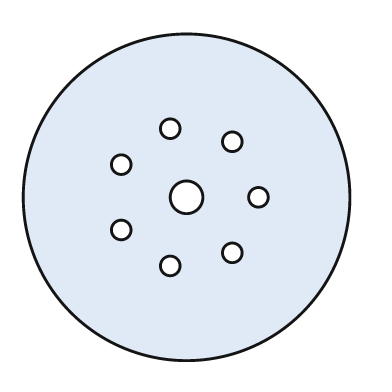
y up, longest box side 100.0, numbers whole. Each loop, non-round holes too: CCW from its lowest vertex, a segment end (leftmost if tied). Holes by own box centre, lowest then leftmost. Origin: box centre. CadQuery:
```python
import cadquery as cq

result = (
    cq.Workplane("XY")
    .moveTo(0.0, 0.0)
    .circle(50.0)
    .moveTo(-5.0, -21.0)
    .circle(3.0)
    .moveTo(14.0, -17.0)
    .circle(3.0)
    .moveTo(-20.0, -10.0)
    .circle(3.0)
    .moveTo(0.0, 0.0)
    .circle(5.0)
    .moveTo(22.0, 0.0)
    .circle(3.0)
    .moveTo(-20.0, 10.0)
    .circle(3.0)
    .moveTo(14.0, 17.0)
    .circle(3.0)
    .moveTo(-5.0, 21.0)
    .circle(3.0)
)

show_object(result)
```